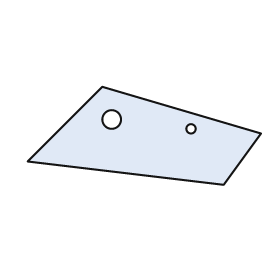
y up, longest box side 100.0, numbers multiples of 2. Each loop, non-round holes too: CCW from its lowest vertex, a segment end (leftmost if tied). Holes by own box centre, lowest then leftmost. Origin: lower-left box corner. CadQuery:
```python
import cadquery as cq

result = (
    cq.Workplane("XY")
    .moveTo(84.0, 0.0)
    .lineTo(100.0, 22.0)
    .lineTo(32.0, 42.0)
    .lineTo(0.0, 10.0)
    .close()
    .moveTo(70.0, 24.0)
    .circle(2.0)
    .moveTo(36.0, 28.0)
    .circle(4.0)
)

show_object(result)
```